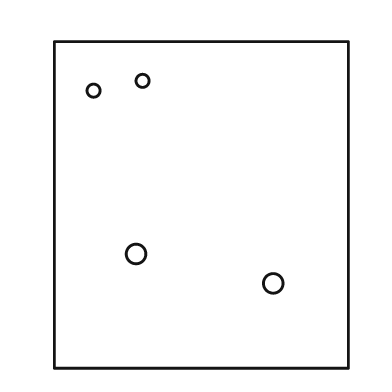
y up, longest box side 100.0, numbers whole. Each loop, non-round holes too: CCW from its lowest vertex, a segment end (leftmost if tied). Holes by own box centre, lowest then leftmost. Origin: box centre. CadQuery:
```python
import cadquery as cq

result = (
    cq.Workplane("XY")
    .moveTo(-45.0, -50.0)
    .lineTo(45.0, -50.0)
    .lineTo(45.0, 50.0)
    .lineTo(-45.0, 50.0)
    .close()
    .moveTo(22.0, -24.0)
    .circle(3.0)
    .moveTo(-20.0, -15.0)
    .circle(3.0)
    .moveTo(-33.0, 35.0)
    .circle(2.0)
    .moveTo(-18.0, 38.0)
    .circle(2.0)
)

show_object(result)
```